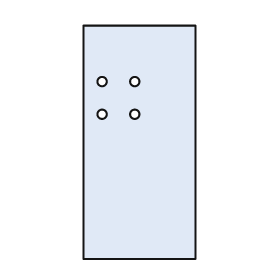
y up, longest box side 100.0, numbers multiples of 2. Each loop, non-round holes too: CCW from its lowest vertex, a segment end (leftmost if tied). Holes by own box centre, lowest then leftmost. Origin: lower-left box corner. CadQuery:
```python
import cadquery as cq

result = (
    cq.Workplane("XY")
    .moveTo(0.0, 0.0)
    .lineTo(48.0, 0.0)
    .lineTo(48.0, 100.0)
    .lineTo(0.0, 100.0)
    .close()
    .moveTo(8.0, 62.0)
    .circle(2.0)
    .moveTo(22.0, 62.0)
    .circle(2.0)
    .moveTo(8.0, 76.0)
    .circle(2.0)
    .moveTo(22.0, 76.0)
    .circle(2.0)
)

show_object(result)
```